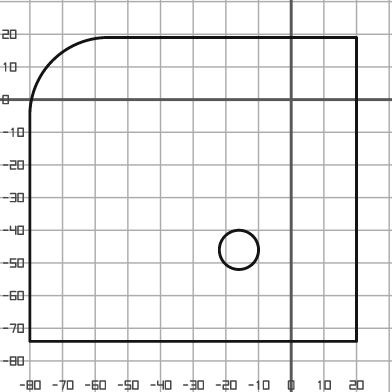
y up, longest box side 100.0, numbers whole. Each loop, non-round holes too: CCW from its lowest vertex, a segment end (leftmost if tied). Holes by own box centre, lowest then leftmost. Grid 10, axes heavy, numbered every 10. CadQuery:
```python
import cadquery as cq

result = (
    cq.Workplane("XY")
    .moveTo(-80.0, -74.0)
    .lineTo(20.0, -74.0)
    .lineTo(20.0, 19.0)
    .lineTo(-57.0, 19.0)
    .threePointArc((-73.0, 12.0), (-80.0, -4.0))
    .close()
    .moveTo(-16.0, -46.0)
    .circle(6.0)
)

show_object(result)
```